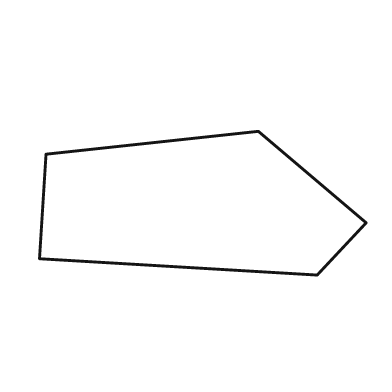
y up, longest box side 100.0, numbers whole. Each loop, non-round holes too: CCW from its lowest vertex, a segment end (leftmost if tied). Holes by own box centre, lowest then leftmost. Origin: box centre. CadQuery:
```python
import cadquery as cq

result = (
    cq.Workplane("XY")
    .moveTo(35.0, -22.0)
    .lineTo(50.0, -6.0)
    .lineTo(17.0, 22.0)
    .lineTo(-48.0, 15.0)
    .lineTo(-50.0, -17.0)
    .close()
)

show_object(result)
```